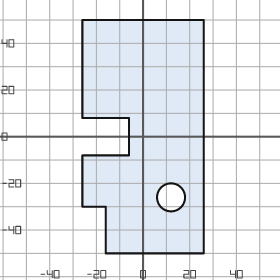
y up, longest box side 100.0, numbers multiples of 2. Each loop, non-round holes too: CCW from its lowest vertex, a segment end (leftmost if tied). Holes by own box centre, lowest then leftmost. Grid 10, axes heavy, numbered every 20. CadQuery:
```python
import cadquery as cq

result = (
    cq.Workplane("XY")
    .moveTo(-16.0, -50.0)
    .lineTo(26.0, -50.0)
    .lineTo(26.0, 50.0)
    .lineTo(-26.0, 50.0)
    .lineTo(-26.0, 8.0)
    .lineTo(-6.0, 8.0)
    .lineTo(-6.0, -8.0)
    .lineTo(-26.0, -8.0)
    .lineTo(-26.0, -30.0)
    .lineTo(-16.0, -30.0)
    .close()
    .moveTo(12.0, -26.0)
    .circle(6.0)
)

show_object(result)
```